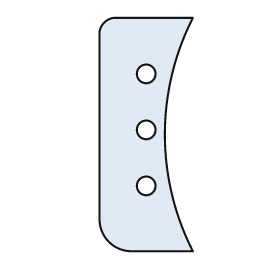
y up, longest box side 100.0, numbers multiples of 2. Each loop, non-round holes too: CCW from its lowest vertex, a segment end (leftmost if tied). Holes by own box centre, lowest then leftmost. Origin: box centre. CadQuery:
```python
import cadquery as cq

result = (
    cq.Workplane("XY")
    .moveTo(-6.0, -50.0)
    .lineTo(20.0, -50.0)
    .threePointArc((8.0, 0.0), (20.0, 50.0))
    .lineTo(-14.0, 50.0)
    .threePointArc((-18.0, 48.0), (-20.0, 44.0))
    .lineTo(-20.0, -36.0)
    .threePointArc((-16.0, -46.0), (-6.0, -50.0))
    .close()
    .moveTo(0.0, -22.0)
    .circle(4.0)
    .moveTo(0.0, 2.0)
    .circle(4.0)
    .moveTo(0.0, 26.0)
    .circle(4.0)
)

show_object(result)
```